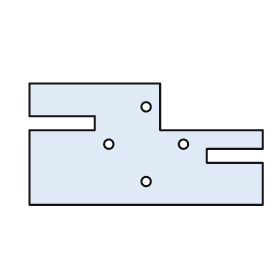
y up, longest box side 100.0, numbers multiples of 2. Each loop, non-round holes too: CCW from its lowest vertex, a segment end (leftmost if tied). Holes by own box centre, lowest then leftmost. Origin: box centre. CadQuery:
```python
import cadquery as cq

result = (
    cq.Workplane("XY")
    .moveTo(-50.0, -26.0)
    .lineTo(50.0, -26.0)
    .lineTo(50.0, -8.0)
    .lineTo(26.0, -8.0)
    .lineTo(26.0, -2.0)
    .lineTo(50.0, -2.0)
    .lineTo(50.0, 6.0)
    .lineTo(6.0, 6.0)
    .lineTo(6.0, 26.0)
    .lineTo(-50.0, 26.0)
    .lineTo(-50.0, 12.0)
    .lineTo(-22.0, 12.0)
    .lineTo(-22.0, 6.0)
    .lineTo(-50.0, 6.0)
    .close()
    .moveTo(0.0, -16.0)
    .circle(2.0)
    .moveTo(-16.0, 0.0)
    .circle(2.0)
    .moveTo(16.0, 0.0)
    .circle(2.0)
    .moveTo(0.0, 16.0)
    .circle(2.0)
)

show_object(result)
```